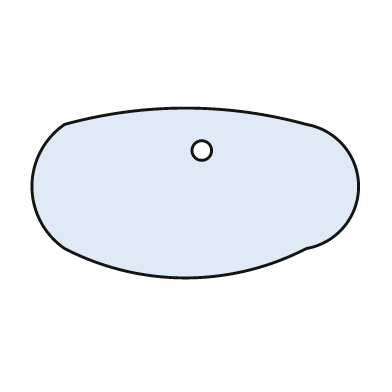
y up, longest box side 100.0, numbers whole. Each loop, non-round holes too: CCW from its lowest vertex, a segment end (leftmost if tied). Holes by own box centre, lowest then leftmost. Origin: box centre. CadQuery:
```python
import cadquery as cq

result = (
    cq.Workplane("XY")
    .moveTo(-40.0, -17.0)
    .threePointArc((-3.0, -26.0), (34.0, -17.0))
    .threePointArc((50.0, 2.0), (34.0, 21.0))
    .threePointArc((-3.0, 26.0), (-40.0, 21.0))
    .threePointArc((-50.0, 2.0), (-40.0, -17.0))
    .close()
    .moveTo(2.0, 13.0)
    .circle(3.0)
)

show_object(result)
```